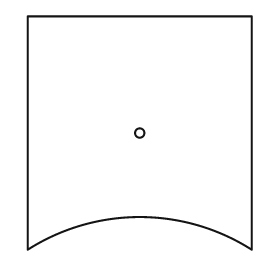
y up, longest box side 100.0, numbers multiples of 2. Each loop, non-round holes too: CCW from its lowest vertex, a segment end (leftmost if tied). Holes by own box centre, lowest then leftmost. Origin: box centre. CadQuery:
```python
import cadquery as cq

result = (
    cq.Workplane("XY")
    .moveTo(-48.0, -50.0)
    .threePointArc((0.0, -36.0), (48.0, -50.0))
    .lineTo(48.0, 50.0)
    .lineTo(-48.0, 50.0)
    .close()
    .moveTo(0.0, 0.0)
    .circle(2.0)
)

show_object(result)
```